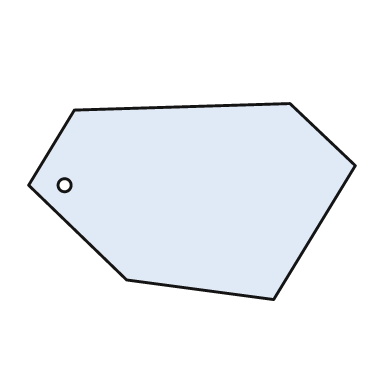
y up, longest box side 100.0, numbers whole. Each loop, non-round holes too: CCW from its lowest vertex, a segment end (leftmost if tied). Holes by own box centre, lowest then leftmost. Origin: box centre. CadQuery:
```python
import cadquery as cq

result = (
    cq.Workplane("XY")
    .moveTo(25.0, -30.0)
    .lineTo(50.0, 11.0)
    .lineTo(30.0, 30.0)
    .lineTo(-36.0, 28.0)
    .lineTo(-50.0, 5.0)
    .lineTo(-20.0, -24.0)
    .close()
    .moveTo(-39.0, 5.0)
    .circle(2.0)
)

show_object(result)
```